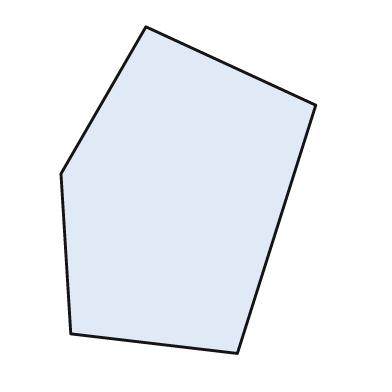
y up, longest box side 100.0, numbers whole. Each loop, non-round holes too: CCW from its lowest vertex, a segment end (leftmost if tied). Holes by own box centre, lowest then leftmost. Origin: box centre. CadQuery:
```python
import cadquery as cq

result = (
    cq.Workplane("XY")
    .moveTo(15.0, -50.0)
    .lineTo(39.0, 26.0)
    .lineTo(-13.0, 50.0)
    .lineTo(-39.0, 5.0)
    .lineTo(-36.0, -44.0)
    .close()
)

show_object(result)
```